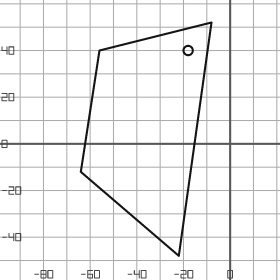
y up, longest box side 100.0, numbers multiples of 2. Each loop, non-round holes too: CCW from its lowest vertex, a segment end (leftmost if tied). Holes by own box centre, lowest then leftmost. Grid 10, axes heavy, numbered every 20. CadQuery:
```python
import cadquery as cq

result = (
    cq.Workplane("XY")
    .moveTo(-22.0, -48.0)
    .lineTo(-8.0, 52.0)
    .lineTo(-56.0, 40.0)
    .lineTo(-64.0, -12.0)
    .close()
    .moveTo(-18.0, 40.0)
    .circle(2.0)
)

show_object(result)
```